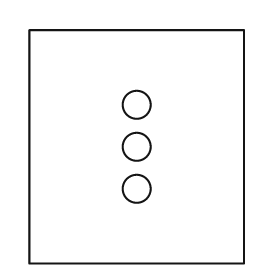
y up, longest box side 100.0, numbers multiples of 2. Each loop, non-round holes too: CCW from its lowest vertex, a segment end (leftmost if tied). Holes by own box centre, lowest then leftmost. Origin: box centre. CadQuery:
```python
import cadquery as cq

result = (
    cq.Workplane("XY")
    .moveTo(-46.0, -50.0)
    .lineTo(46.0, -50.0)
    .lineTo(46.0, 50.0)
    .lineTo(-46.0, 50.0)
    .close()
    .moveTo(0.0, -18.0)
    .circle(6.0)
    .moveTo(0.0, 0.0)
    .circle(6.0)
    .moveTo(0.0, 18.0)
    .circle(6.0)
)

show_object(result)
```